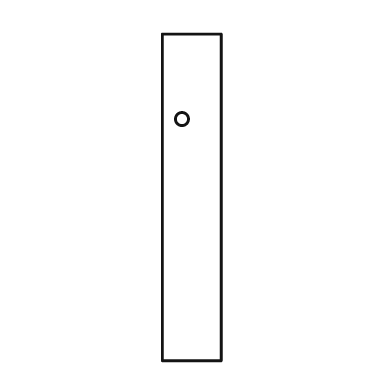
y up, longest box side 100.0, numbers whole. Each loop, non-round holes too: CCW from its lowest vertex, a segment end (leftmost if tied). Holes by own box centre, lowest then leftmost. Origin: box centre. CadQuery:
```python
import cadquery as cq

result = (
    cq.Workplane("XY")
    .moveTo(-9.0, -50.0)
    .lineTo(9.0, -50.0)
    .lineTo(9.0, 50.0)
    .lineTo(-9.0, 50.0)
    .close()
    .moveTo(-3.0, 24.0)
    .circle(2.0)
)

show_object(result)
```